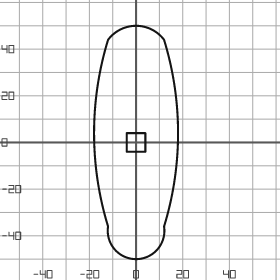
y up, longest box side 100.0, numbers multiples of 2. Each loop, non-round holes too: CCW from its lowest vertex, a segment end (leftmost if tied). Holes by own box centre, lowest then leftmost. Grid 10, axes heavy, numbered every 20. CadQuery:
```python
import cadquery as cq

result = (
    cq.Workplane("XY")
    .moveTo(-12.0, -36.0)
    .threePointArc((0.0, -50.0), (12.0, -36.0))
    .threePointArc((18.0, 4.0), (12.0, 44.0))
    .threePointArc((0.0, 50.0), (-12.0, 44.0))
    .threePointArc((-18.0, 4.0), (-12.0, -36.0))
    .close()
    .moveTo(-4.0, -4.0)
    .lineTo(4.0, -4.0)
    .lineTo(4.0, 4.0)
    .lineTo(-4.0, 4.0)
    .close()
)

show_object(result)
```